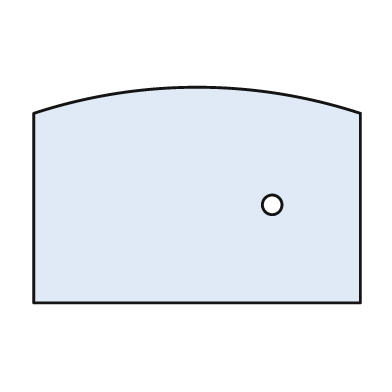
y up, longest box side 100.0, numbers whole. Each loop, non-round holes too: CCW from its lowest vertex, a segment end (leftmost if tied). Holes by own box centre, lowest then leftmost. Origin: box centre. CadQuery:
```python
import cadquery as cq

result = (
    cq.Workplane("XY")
    .moveTo(-50.0, -33.0)
    .lineTo(50.0, -33.0)
    .lineTo(50.0, 25.0)
    .threePointArc((0.0, 33.0), (-50.0, 25.0))
    .close()
    .moveTo(23.0, -3.0)
    .circle(3.0)
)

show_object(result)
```